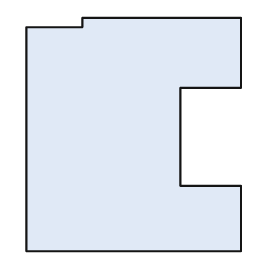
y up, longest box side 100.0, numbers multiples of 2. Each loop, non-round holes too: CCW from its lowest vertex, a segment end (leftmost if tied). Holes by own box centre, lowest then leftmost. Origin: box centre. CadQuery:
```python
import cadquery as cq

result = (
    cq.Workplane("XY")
    .moveTo(-46.0, -50.0)
    .lineTo(46.0, -50.0)
    .lineTo(46.0, -22.0)
    .lineTo(20.0, -22.0)
    .lineTo(20.0, 20.0)
    .lineTo(46.0, 20.0)
    .lineTo(46.0, 50.0)
    .lineTo(-22.0, 50.0)
    .lineTo(-22.0, 46.0)
    .lineTo(-46.0, 46.0)
    .close()
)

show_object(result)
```